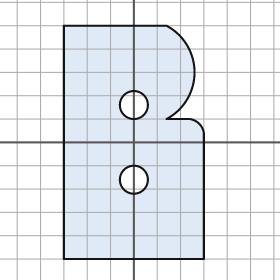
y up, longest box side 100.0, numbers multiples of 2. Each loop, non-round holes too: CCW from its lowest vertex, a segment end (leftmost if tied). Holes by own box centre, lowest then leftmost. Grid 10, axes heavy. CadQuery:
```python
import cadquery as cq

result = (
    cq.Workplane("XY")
    .moveTo(-30.0, -50.0)
    .lineTo(30.0, -50.0)
    .lineTo(30.0, 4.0)
    .threePointArc((28.0, 8.0), (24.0, 10.0))
    .lineTo(14.0, 10.0)
    .threePointArc((26.0, 30.0), (14.0, 50.0))
    .lineTo(-30.0, 50.0)
    .close()
    .moveTo(0.0, -16.0)
    .circle(6.0)
    .moveTo(0.0, 16.0)
    .circle(6.0)
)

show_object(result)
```